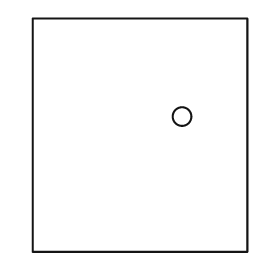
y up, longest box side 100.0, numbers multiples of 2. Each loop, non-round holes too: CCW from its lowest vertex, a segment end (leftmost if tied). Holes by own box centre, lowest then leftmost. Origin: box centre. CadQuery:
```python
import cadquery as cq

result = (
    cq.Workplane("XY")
    .moveTo(-46.0, -50.0)
    .lineTo(46.0, -50.0)
    .lineTo(46.0, 50.0)
    .lineTo(-46.0, 50.0)
    .close()
    .moveTo(18.0, 8.0)
    .circle(4.0)
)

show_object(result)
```